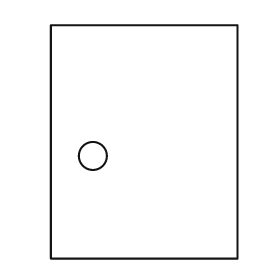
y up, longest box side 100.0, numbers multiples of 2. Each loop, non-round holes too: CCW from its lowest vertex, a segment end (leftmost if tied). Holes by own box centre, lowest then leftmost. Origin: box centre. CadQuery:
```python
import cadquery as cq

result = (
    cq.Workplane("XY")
    .moveTo(-40.0, -50.0)
    .lineTo(40.0, -50.0)
    .lineTo(40.0, 50.0)
    .lineTo(-40.0, 50.0)
    .close()
    .moveTo(-22.0, -6.0)
    .circle(6.0)
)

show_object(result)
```